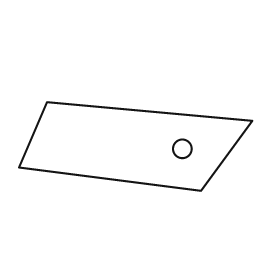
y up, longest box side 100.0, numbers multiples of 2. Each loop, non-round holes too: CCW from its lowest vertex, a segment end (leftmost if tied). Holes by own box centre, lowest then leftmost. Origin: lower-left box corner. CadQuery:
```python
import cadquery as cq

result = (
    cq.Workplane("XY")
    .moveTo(78.0, 0.0)
    .lineTo(100.0, 30.0)
    .lineTo(12.0, 38.0)
    .lineTo(0.0, 10.0)
    .close()
    .moveTo(70.0, 18.0)
    .circle(4.0)
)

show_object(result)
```